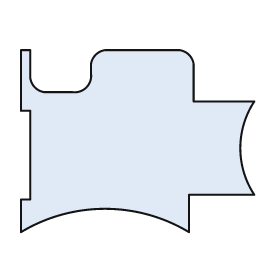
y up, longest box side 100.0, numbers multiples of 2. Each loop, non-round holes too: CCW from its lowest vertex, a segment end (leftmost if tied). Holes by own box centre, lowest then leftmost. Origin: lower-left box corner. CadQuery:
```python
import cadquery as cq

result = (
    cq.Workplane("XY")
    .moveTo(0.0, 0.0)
    .threePointArc((36.0, 10.0), (72.0, 0.0))
    .lineTo(72.0, 16.0)
    .lineTo(100.0, 16.0)
    .threePointArc((94.0, 36.0), (100.0, 56.0))
    .lineTo(74.0, 56.0)
    .lineTo(74.0, 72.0)
    .threePointArc((72.0, 76.0), (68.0, 78.0))
    .lineTo(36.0, 78.0)
    .threePointArc((32.0, 76.0), (30.0, 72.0))
    .lineTo(30.0, 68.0)
    .threePointArc((28.0, 62.0), (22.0, 60.0))
    .lineTo(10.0, 60.0)
    .threePointArc((6.0, 62.0), (4.0, 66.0))
    .lineTo(4.0, 78.0)
    .lineTo(0.0, 78.0)
    .lineTo(0.0, 52.0)
    .lineTo(4.0, 52.0)
    .lineTo(4.0, 14.0)
    .lineTo(0.0, 14.0)
    .close()
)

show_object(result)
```